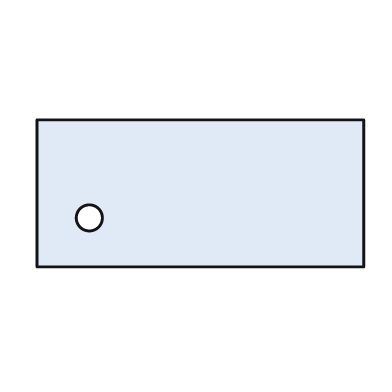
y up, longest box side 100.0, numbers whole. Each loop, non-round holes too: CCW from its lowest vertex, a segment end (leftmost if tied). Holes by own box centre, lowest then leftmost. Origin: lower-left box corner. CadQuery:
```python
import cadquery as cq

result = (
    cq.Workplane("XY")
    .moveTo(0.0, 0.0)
    .lineTo(100.0, 0.0)
    .lineTo(100.0, 45.0)
    .lineTo(0.0, 45.0)
    .close()
    .moveTo(16.0, 15.0)
    .circle(4.0)
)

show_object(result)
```